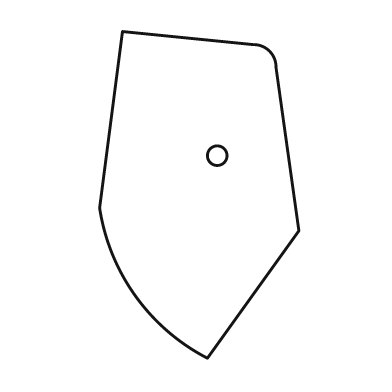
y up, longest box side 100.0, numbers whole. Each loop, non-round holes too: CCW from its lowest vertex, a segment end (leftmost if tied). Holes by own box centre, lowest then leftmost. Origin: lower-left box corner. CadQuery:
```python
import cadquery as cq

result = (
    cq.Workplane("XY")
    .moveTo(33.0, 0.0)
    .lineTo(61.0, 39.0)
    .lineTo(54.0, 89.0)
    .threePointArc((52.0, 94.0), (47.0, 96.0))
    .lineTo(7.0, 100.0)
    .lineTo(0.0, 46.0)
    .threePointArc((11.0, 19.0), (33.0, 0.0))
    .close()
    .moveTo(36.0, 62.0)
    .circle(3.0)
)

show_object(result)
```